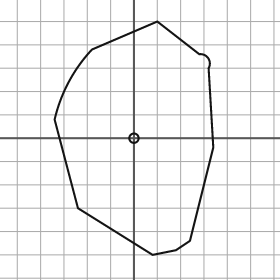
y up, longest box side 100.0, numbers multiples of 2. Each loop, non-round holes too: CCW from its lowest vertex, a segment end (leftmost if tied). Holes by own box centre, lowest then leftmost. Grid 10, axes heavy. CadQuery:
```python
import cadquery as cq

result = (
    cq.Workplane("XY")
    .moveTo(8.0, -50.0)
    .lineTo(18.0, -48.0)
    .lineTo(24.0, -44.0)
    .lineTo(34.0, -4.0)
    .lineTo(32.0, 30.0)
    .threePointArc((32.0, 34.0), (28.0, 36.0))
    .lineTo(10.0, 50.0)
    .lineTo(-18.0, 38.0)
    .threePointArc((-28.0, 24.0), (-34.0, 8.0))
    .lineTo(-24.0, -30.0)
    .close()
    .moveTo(0.0, 0.0)
    .circle(2.0)
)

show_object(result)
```